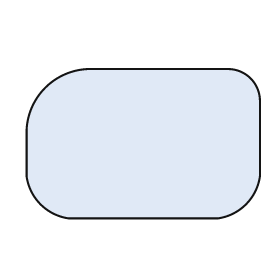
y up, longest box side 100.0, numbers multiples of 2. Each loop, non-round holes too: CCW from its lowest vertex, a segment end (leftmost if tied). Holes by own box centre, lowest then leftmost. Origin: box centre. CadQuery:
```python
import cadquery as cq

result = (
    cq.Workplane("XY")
    .moveTo(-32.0, -32.0)
    .lineTo(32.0, -32.0)
    .threePointArc((44.0, -26.0), (50.0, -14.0))
    .lineTo(50.0, 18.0)
    .threePointArc((46.0, 28.0), (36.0, 32.0))
    .lineTo(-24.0, 32.0)
    .threePointArc((-42.0, 24.0), (-50.0, 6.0))
    .lineTo(-50.0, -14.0)
    .threePointArc((-44.0, -26.0), (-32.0, -32.0))
    .close()
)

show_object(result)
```